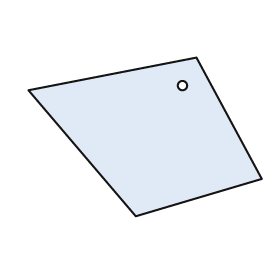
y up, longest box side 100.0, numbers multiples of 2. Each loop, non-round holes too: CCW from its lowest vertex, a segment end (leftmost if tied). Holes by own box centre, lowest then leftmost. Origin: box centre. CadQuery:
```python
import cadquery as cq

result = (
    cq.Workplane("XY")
    .moveTo(-4.0, -34.0)
    .lineTo(50.0, -18.0)
    .lineTo(22.0, 34.0)
    .lineTo(-50.0, 20.0)
    .close()
    .moveTo(16.0, 22.0)
    .circle(2.0)
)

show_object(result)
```